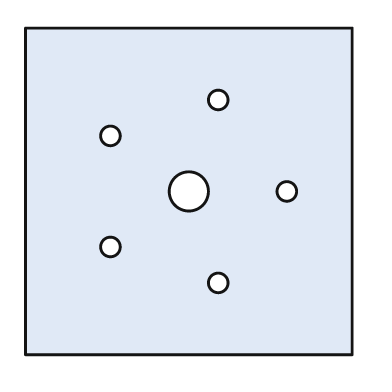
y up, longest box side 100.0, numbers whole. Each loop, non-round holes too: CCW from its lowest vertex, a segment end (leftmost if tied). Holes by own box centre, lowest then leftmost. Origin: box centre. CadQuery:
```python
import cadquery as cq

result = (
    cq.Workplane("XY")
    .moveTo(-50.0, -50.0)
    .lineTo(50.0, -50.0)
    .lineTo(50.0, 50.0)
    .lineTo(-50.0, 50.0)
    .close()
    .moveTo(9.0, -28.0)
    .circle(3.0)
    .moveTo(-24.0, -17.0)
    .circle(3.0)
    .moveTo(0.0, 0.0)
    .circle(6.0)
    .moveTo(30.0, 0.0)
    .circle(3.0)
    .moveTo(-24.0, 17.0)
    .circle(3.0)
    .moveTo(9.0, 28.0)
    .circle(3.0)
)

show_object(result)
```